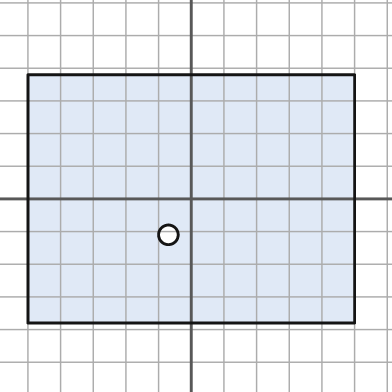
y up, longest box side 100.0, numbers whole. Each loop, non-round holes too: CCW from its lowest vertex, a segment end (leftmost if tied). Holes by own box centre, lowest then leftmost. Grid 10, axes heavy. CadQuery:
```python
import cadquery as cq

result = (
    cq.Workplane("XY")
    .moveTo(-50.0, -38.0)
    .lineTo(50.0, -38.0)
    .lineTo(50.0, 38.0)
    .lineTo(-50.0, 38.0)
    .close()
    .moveTo(-7.0, -11.0)
    .circle(3.0)
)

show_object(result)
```